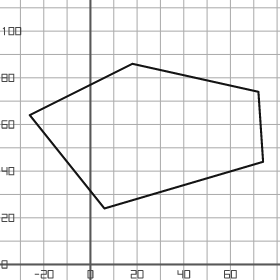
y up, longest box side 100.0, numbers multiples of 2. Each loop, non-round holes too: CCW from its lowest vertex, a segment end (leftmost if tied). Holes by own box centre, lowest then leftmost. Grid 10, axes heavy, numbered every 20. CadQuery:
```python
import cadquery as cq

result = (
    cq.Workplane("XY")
    .moveTo(6.0, 24.0)
    .lineTo(74.0, 44.0)
    .lineTo(72.0, 74.0)
    .lineTo(18.0, 86.0)
    .lineTo(-26.0, 64.0)
    .close()
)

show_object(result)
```